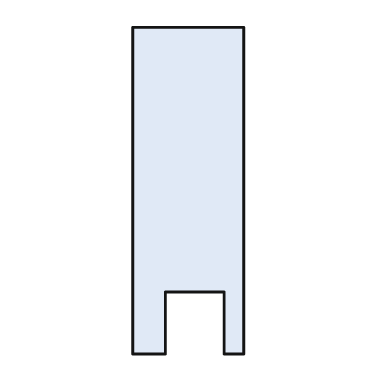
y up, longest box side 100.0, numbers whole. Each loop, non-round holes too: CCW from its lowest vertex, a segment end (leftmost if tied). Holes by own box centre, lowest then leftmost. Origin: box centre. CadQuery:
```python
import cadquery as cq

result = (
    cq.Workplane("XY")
    .moveTo(-17.0, -50.0)
    .lineTo(-7.0, -50.0)
    .lineTo(-7.0, -31.0)
    .lineTo(11.0, -31.0)
    .lineTo(11.0, -50.0)
    .lineTo(17.0, -50.0)
    .lineTo(17.0, 50.0)
    .lineTo(-17.0, 50.0)
    .close()
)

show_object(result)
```